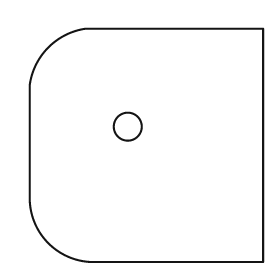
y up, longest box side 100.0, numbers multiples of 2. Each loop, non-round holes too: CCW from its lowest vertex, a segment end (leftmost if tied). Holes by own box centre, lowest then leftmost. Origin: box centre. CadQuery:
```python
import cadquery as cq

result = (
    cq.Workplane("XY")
    .moveTo(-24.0, -50.0)
    .lineTo(50.0, -50.0)
    .lineTo(50.0, 50.0)
    .lineTo(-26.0, 50.0)
    .threePointArc((-42.0, 42.0), (-50.0, 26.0))
    .lineTo(-50.0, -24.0)
    .threePointArc((-42.0, -42.0), (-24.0, -50.0))
    .close()
    .moveTo(-8.0, 8.0)
    .circle(6.0)
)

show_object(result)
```